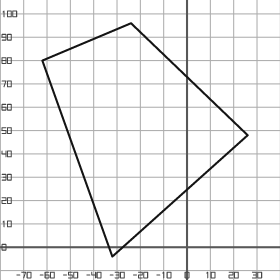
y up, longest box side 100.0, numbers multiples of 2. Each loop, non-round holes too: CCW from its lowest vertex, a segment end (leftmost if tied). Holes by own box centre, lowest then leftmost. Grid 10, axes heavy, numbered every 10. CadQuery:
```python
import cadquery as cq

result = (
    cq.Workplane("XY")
    .moveTo(-32.0, -4.0)
    .lineTo(26.0, 48.0)
    .lineTo(-24.0, 96.0)
    .lineTo(-62.0, 80.0)
    .close()
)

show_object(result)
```